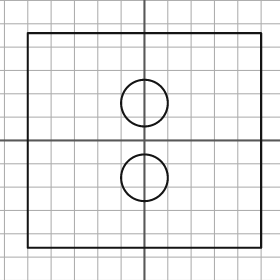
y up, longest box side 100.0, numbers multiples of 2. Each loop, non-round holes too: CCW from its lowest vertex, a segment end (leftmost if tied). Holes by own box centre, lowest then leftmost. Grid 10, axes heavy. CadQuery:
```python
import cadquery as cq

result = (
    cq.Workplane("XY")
    .moveTo(-50.0, -46.0)
    .lineTo(50.0, -46.0)
    .lineTo(50.0, 46.0)
    .lineTo(-50.0, 46.0)
    .close()
    .moveTo(0.0, -16.0)
    .circle(10.0)
    .moveTo(0.0, 16.0)
    .circle(10.0)
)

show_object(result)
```